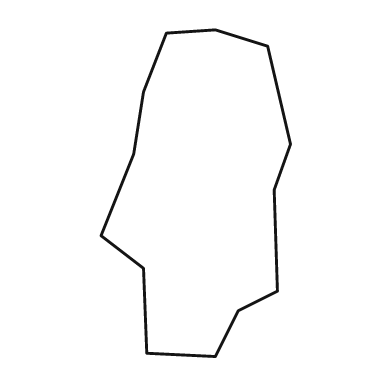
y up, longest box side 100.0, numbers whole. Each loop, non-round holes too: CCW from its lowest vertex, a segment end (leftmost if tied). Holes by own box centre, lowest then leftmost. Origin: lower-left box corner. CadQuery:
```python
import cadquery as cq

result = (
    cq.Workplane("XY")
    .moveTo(35.0, 0.0)
    .lineTo(42.0, 14.0)
    .lineTo(54.0, 20.0)
    .lineTo(53.0, 51.0)
    .lineTo(58.0, 65.0)
    .lineTo(51.0, 95.0)
    .lineTo(35.0, 100.0)
    .lineTo(20.0, 99.0)
    .lineTo(13.0, 81.0)
    .lineTo(10.0, 62.0)
    .lineTo(0.0, 37.0)
    .lineTo(13.0, 27.0)
    .lineTo(14.0, 1.0)
    .close()
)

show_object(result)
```